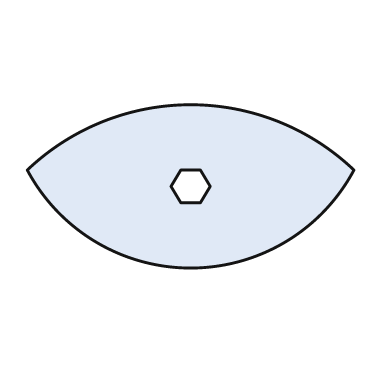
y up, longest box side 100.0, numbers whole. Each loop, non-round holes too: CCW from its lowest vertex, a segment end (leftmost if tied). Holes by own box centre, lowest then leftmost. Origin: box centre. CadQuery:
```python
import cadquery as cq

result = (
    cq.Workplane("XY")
    .moveTo(-50.0, 5.0)
    .threePointArc((0.0, -25.0), (50.0, 5.0))
    .threePointArc((0.0, 25.0), (-50.0, 5.0))
    .close()
    .moveTo(-3.0, -5.0)
    .lineTo(3.0, -5.0)
    .lineTo(6.0, 0.0)
    .lineTo(3.0, 5.0)
    .lineTo(-3.0, 5.0)
    .lineTo(-6.0, 0.0)
    .close()
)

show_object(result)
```